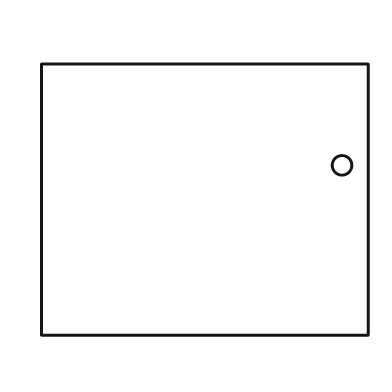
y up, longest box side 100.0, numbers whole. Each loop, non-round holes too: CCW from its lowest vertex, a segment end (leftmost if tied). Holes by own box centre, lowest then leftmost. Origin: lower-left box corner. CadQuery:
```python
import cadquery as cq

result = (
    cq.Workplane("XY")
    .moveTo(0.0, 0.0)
    .lineTo(100.0, 0.0)
    .lineTo(100.0, 83.0)
    .lineTo(0.0, 83.0)
    .close()
    .moveTo(92.0, 52.0)
    .circle(3.0)
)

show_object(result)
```